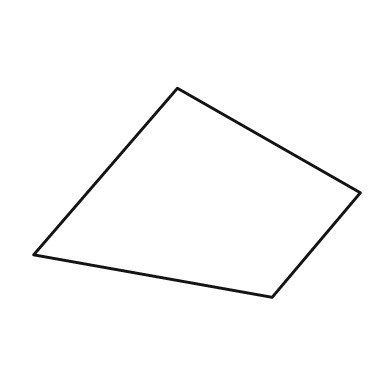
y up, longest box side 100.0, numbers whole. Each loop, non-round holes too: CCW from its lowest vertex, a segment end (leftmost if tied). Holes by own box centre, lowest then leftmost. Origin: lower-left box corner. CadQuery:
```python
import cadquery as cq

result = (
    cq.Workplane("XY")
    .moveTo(73.0, 0.0)
    .lineTo(100.0, 32.0)
    .lineTo(44.0, 64.0)
    .lineTo(0.0, 13.0)
    .close()
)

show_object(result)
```